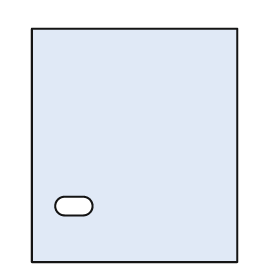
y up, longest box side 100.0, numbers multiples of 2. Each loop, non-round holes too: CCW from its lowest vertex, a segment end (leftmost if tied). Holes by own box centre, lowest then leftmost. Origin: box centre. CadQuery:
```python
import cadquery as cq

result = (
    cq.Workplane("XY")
    .moveTo(-44.0, -50.0)
    .lineTo(44.0, -50.0)
    .lineTo(44.0, 50.0)
    .lineTo(-44.0, 50.0)
    .close()
    .moveTo(-30.0, -30.0)
    .lineTo(-22.0, -30.0)
    .threePointArc((-18.0, -26.0), (-22.0, -22.0))
    .lineTo(-30.0, -22.0)
    .threePointArc((-34.0, -26.0), (-30.0, -30.0))
    .close()
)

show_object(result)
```